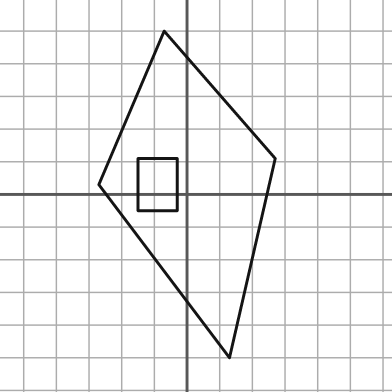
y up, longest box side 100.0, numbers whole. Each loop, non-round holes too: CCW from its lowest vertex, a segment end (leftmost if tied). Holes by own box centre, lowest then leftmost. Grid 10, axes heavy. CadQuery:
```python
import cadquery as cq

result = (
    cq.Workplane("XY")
    .moveTo(13.0, -50.0)
    .lineTo(27.0, 11.0)
    .lineTo(-7.0, 50.0)
    .lineTo(-27.0, 3.0)
    .close()
    .moveTo(-15.0, -5.0)
    .lineTo(-3.0, -5.0)
    .lineTo(-3.0, 11.0)
    .lineTo(-15.0, 11.0)
    .close()
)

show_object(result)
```